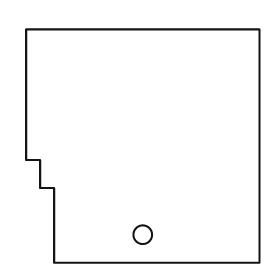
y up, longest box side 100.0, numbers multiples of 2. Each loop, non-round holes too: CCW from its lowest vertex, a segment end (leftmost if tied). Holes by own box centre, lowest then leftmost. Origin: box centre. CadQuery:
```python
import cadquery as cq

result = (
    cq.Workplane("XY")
    .moveTo(-38.0, -50.0)
    .lineTo(50.0, -50.0)
    .lineTo(50.0, 50.0)
    .lineTo(-50.0, 50.0)
    .lineTo(-50.0, -6.0)
    .lineTo(-44.0, -6.0)
    .lineTo(-44.0, -18.0)
    .lineTo(-38.0, -18.0)
    .close()
    .moveTo(0.0, -38.0)
    .circle(4.0)
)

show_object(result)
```